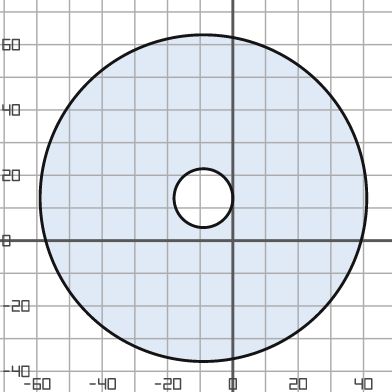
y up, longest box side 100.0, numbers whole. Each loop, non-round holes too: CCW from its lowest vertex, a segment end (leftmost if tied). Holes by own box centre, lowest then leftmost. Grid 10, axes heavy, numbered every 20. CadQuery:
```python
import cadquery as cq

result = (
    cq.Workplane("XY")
    .moveTo(-9.0, 13.0)
    .circle(50.0)
    .moveTo(-9.0, 13.0)
    .circle(9.0)
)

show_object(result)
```